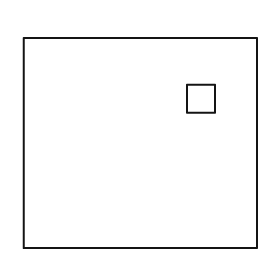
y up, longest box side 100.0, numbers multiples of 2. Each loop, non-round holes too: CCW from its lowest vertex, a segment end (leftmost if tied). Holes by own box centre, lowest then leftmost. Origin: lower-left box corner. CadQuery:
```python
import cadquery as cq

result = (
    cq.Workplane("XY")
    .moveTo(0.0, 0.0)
    .lineTo(100.0, 0.0)
    .lineTo(100.0, 90.0)
    .lineTo(0.0, 90.0)
    .close()
    .moveTo(70.0, 58.0)
    .lineTo(82.0, 58.0)
    .lineTo(82.0, 70.0)
    .lineTo(70.0, 70.0)
    .close()
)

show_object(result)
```